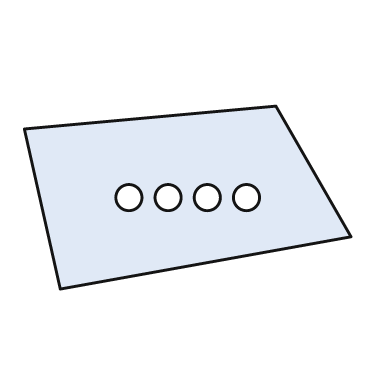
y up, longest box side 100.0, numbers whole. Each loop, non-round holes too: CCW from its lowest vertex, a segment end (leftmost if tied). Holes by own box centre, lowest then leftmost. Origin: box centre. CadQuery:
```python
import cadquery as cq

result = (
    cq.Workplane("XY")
    .moveTo(-39.0, -28.0)
    .lineTo(50.0, -12.0)
    .lineTo(27.0, 28.0)
    .lineTo(-50.0, 21.0)
    .close()
    .moveTo(-18.0, 0.0)
    .circle(4.0)
    .moveTo(-6.0, 0.0)
    .circle(4.0)
    .moveTo(6.0, 0.0)
    .circle(4.0)
    .moveTo(18.0, 0.0)
    .circle(4.0)
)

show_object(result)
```